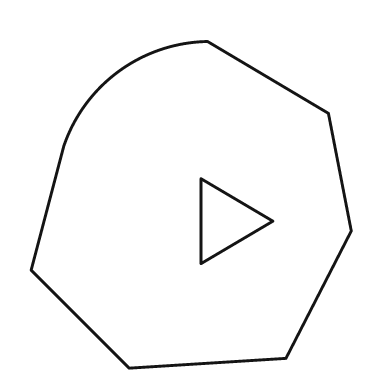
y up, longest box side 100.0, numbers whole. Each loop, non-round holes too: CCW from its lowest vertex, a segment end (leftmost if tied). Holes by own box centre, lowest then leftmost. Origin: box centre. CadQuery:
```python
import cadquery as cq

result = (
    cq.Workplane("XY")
    .moveTo(-19.0, -50.0)
    .lineTo(29.0, -47.0)
    .lineTo(49.0, -8.0)
    .lineTo(42.0, 28.0)
    .lineTo(5.0, 50.0)
    .threePointArc((-22.0, 41.0), (-39.0, 18.0))
    .lineTo(-49.0, -20.0)
    .close()
    .moveTo(3.0, -18.0)
    .lineTo(25.0, -5.0)
    .lineTo(3.0, 8.0)
    .close()
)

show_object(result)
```